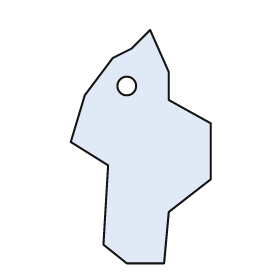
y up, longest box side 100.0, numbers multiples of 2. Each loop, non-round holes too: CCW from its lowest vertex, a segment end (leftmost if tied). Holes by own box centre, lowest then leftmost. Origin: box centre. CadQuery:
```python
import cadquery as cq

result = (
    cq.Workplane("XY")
    .moveTo(-6.0, -50.0)
    .lineTo(10.0, -50.0)
    .lineTo(12.0, -28.0)
    .lineTo(30.0, -14.0)
    .lineTo(30.0, 10.0)
    .lineTo(12.0, 20.0)
    .lineTo(12.0, 32.0)
    .lineTo(4.0, 50.0)
    .lineTo(-4.0, 42.0)
    .lineTo(-12.0, 38.0)
    .lineTo(-24.0, 22.0)
    .lineTo(-30.0, 2.0)
    .lineTo(-14.0, -8.0)
    .lineTo(-16.0, -42.0)
    .close()
    .moveTo(-6.0, 26.0)
    .circle(4.0)
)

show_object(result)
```